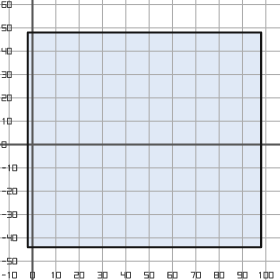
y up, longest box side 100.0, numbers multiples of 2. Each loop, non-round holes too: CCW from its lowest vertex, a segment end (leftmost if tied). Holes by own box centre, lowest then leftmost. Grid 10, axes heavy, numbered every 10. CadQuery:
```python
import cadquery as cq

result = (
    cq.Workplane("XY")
    .moveTo(-2.0, -44.0)
    .lineTo(98.0, -44.0)
    .lineTo(98.0, 48.0)
    .lineTo(-2.0, 48.0)
    .close()
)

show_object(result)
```